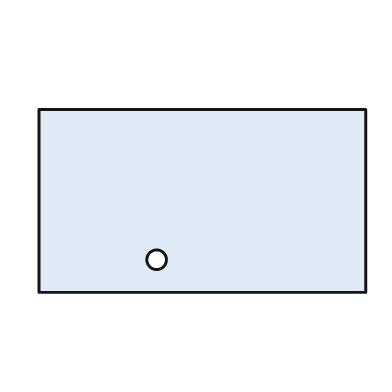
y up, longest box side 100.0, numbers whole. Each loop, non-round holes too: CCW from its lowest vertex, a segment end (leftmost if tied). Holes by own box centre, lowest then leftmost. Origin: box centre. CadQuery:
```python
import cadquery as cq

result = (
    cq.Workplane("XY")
    .moveTo(-50.0, -28.0)
    .lineTo(50.0, -28.0)
    .lineTo(50.0, 28.0)
    .lineTo(-50.0, 28.0)
    .close()
    .moveTo(-14.0, -18.0)
    .circle(3.0)
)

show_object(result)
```